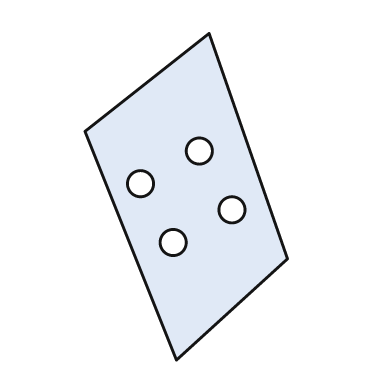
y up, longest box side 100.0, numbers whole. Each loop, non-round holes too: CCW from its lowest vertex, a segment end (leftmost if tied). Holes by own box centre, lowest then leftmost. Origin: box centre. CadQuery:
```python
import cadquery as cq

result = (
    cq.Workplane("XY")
    .moveTo(-3.0, -50.0)
    .lineTo(31.0, -19.0)
    .lineTo(7.0, 50.0)
    .lineTo(-31.0, 20.0)
    .close()
    .moveTo(-4.0, -14.0)
    .circle(4.0)
    .moveTo(14.0, -4.0)
    .circle(4.0)
    .moveTo(-14.0, 4.0)
    .circle(4.0)
    .moveTo(4.0, 14.0)
    .circle(4.0)
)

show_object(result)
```